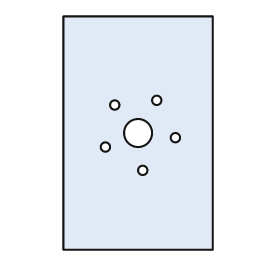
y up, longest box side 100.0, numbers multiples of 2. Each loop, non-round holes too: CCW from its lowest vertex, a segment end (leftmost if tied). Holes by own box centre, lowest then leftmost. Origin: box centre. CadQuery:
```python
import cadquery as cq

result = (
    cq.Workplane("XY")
    .moveTo(-32.0, -50.0)
    .lineTo(32.0, -50.0)
    .lineTo(32.0, 50.0)
    .lineTo(-32.0, 50.0)
    .close()
    .moveTo(2.0, -16.0)
    .circle(2.0)
    .moveTo(-14.0, -6.0)
    .circle(2.0)
    .moveTo(16.0, -2.0)
    .circle(2.0)
    .moveTo(0.0, 0.0)
    .circle(6.0)
    .moveTo(-10.0, 12.0)
    .circle(2.0)
    .moveTo(8.0, 14.0)
    .circle(2.0)
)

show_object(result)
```